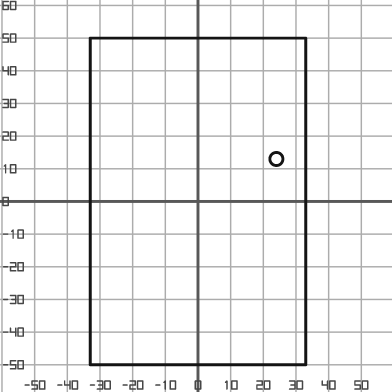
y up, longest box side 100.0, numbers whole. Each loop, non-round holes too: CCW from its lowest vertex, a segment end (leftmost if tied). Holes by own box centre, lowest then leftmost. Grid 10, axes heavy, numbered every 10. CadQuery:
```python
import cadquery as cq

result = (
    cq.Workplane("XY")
    .moveTo(-33.0, -50.0)
    .lineTo(33.0, -50.0)
    .lineTo(33.0, 50.0)
    .lineTo(-33.0, 50.0)
    .close()
    .moveTo(24.0, 13.0)
    .circle(2.0)
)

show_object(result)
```